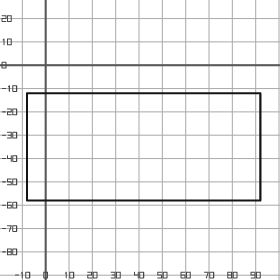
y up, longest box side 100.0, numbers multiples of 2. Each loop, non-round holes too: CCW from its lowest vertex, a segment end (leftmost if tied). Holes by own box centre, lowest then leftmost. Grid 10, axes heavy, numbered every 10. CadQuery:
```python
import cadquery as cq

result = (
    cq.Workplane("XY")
    .moveTo(-8.0, -58.0)
    .lineTo(92.0, -58.0)
    .lineTo(92.0, -12.0)
    .lineTo(-8.0, -12.0)
    .close()
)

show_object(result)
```